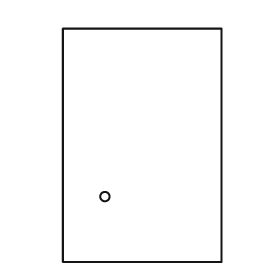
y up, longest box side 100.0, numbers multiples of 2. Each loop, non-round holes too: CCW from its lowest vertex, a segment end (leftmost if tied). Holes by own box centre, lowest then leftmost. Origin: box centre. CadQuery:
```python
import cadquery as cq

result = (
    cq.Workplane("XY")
    .moveTo(-34.0, -50.0)
    .lineTo(34.0, -50.0)
    .lineTo(34.0, 50.0)
    .lineTo(-34.0, 50.0)
    .close()
    .moveTo(-16.0, -22.0)
    .circle(2.0)
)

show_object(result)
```